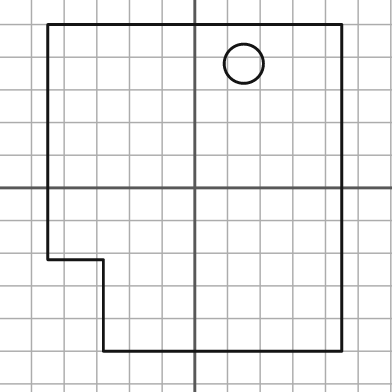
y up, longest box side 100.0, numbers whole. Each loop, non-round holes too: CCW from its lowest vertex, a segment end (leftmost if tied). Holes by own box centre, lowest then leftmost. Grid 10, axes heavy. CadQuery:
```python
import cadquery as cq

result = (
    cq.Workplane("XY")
    .moveTo(-28.0, -50.0)
    .lineTo(45.0, -50.0)
    .lineTo(45.0, 50.0)
    .lineTo(-45.0, 50.0)
    .lineTo(-45.0, -22.0)
    .lineTo(-28.0, -22.0)
    .close()
    .moveTo(15.0, 38.0)
    .circle(6.0)
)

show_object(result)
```